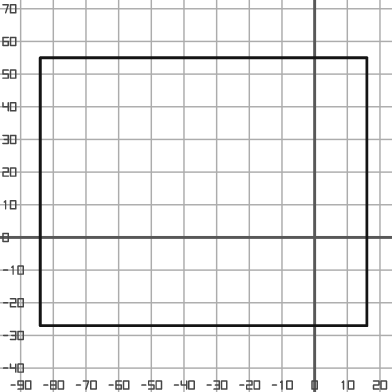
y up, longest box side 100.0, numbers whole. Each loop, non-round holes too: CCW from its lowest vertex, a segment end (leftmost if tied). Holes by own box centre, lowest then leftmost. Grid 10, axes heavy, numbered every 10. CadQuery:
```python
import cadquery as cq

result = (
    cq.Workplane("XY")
    .moveTo(-84.0, -27.0)
    .lineTo(16.0, -27.0)
    .lineTo(16.0, 55.0)
    .lineTo(-84.0, 55.0)
    .close()
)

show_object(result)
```